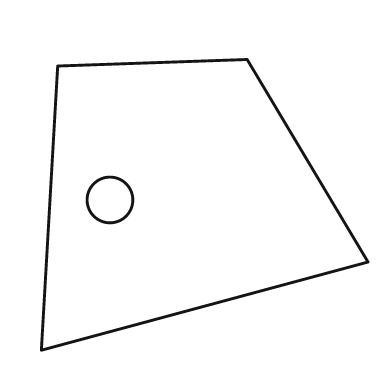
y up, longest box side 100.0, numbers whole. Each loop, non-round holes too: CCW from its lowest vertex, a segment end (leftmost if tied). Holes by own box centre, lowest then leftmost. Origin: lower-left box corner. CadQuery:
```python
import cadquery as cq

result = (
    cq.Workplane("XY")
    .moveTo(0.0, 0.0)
    .lineTo(100.0, 27.0)
    .lineTo(63.0, 89.0)
    .lineTo(5.0, 87.0)
    .close()
    .moveTo(21.0, 46.0)
    .circle(7.0)
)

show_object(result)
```